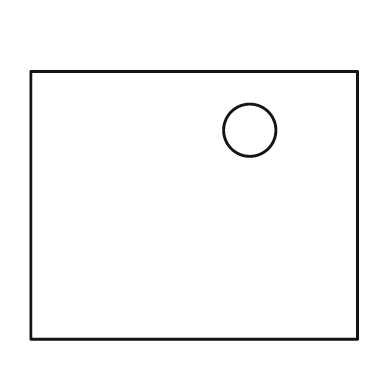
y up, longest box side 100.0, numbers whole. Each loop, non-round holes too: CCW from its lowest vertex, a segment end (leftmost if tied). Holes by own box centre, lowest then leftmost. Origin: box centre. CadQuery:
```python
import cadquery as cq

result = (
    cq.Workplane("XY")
    .moveTo(-50.0, -41.0)
    .lineTo(50.0, -41.0)
    .lineTo(50.0, 41.0)
    .lineTo(-50.0, 41.0)
    .close()
    .moveTo(17.0, 23.0)
    .circle(8.0)
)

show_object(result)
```